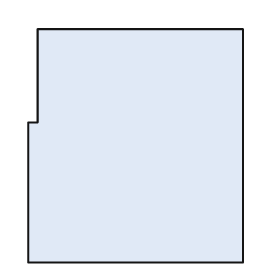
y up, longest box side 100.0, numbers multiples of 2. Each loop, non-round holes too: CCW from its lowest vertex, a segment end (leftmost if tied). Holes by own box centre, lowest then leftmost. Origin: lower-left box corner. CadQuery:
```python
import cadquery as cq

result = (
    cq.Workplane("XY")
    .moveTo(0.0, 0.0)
    .lineTo(92.0, 0.0)
    .lineTo(92.0, 100.0)
    .lineTo(4.0, 100.0)
    .lineTo(4.0, 60.0)
    .lineTo(0.0, 60.0)
    .close()
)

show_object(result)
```